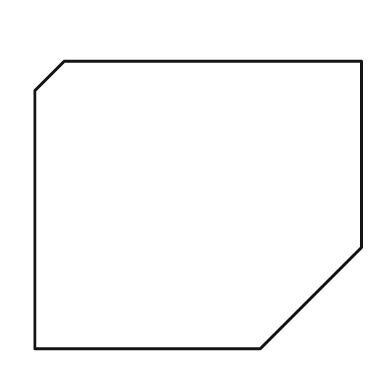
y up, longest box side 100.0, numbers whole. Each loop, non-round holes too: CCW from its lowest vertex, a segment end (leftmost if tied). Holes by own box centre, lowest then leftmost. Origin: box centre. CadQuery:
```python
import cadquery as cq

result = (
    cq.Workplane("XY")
    .moveTo(-50.0, -44.0)
    .lineTo(19.0, -44.0)
    .lineTo(50.0, -13.0)
    .lineTo(50.0, 44.0)
    .lineTo(-41.0, 44.0)
    .lineTo(-50.0, 35.0)
    .close()
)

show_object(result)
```